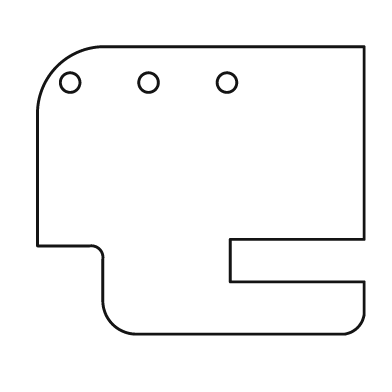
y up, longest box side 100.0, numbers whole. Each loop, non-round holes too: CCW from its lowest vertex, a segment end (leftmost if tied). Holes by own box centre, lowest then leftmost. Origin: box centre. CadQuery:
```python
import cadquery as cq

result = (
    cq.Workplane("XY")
    .moveTo(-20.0, -44.0)
    .lineTo(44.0, -44.0)
    .threePointArc((48.0, -42.0), (50.0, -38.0))
    .lineTo(50.0, -28.0)
    .lineTo(9.0, -28.0)
    .lineTo(9.0, -15.0)
    .lineTo(50.0, -15.0)
    .lineTo(50.0, 44.0)
    .lineTo(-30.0, 44.0)
    .threePointArc((-44.0, 38.0), (-50.0, 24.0))
    .lineTo(-50.0, -17.0)
    .lineTo(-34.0, -17.0)
    .threePointArc((-31.0, -18.0), (-30.0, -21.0))
    .lineTo(-30.0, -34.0)
    .threePointArc((-27.0, -41.0), (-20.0, -44.0))
    .close()
    .moveTo(-40.0, 33.0)
    .circle(3.0)
    .moveTo(-16.0, 33.0)
    .circle(3.0)
    .moveTo(8.0, 33.0)
    .circle(3.0)
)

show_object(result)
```